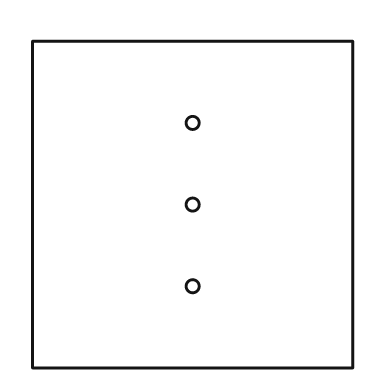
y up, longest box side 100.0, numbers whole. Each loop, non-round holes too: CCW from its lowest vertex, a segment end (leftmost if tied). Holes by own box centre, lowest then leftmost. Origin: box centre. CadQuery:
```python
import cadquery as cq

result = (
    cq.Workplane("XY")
    .moveTo(-49.0, -50.0)
    .lineTo(49.0, -50.0)
    .lineTo(49.0, 50.0)
    .lineTo(-49.0, 50.0)
    .close()
    .moveTo(0.0, -25.0)
    .circle(2.0)
    .moveTo(0.0, 0.0)
    .circle(2.0)
    .moveTo(0.0, 25.0)
    .circle(2.0)
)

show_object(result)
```